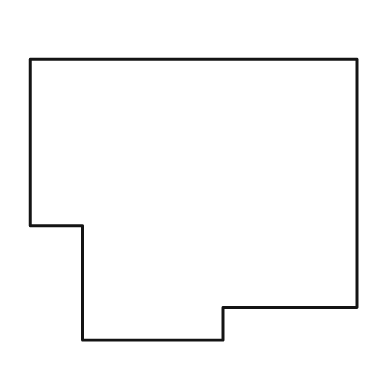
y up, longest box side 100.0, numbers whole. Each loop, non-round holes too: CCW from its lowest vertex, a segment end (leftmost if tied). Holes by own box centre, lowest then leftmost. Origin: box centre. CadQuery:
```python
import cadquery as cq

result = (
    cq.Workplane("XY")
    .moveTo(-34.0, -43.0)
    .lineTo(9.0, -43.0)
    .lineTo(9.0, -33.0)
    .lineTo(50.0, -33.0)
    .lineTo(50.0, 43.0)
    .lineTo(-50.0, 43.0)
    .lineTo(-50.0, -8.0)
    .lineTo(-34.0, -8.0)
    .close()
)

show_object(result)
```